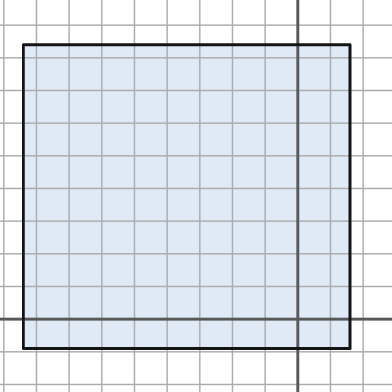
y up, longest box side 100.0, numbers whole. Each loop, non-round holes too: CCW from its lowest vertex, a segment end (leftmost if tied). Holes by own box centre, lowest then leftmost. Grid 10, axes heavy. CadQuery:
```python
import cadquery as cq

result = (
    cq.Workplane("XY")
    .moveTo(-84.0, -9.0)
    .lineTo(16.0, -9.0)
    .lineTo(16.0, 84.0)
    .lineTo(-84.0, 84.0)
    .close()
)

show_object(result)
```